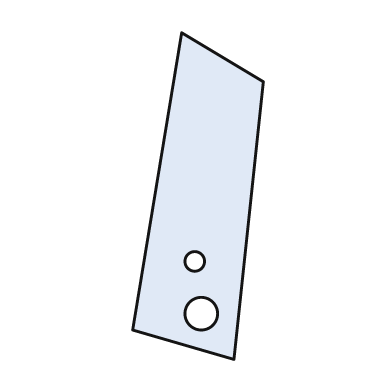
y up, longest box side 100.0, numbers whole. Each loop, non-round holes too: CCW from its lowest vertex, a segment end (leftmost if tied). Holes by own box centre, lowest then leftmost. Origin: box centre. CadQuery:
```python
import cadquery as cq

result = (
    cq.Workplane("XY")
    .moveTo(11.0, -50.0)
    .lineTo(20.0, 35.0)
    .lineTo(-5.0, 50.0)
    .lineTo(-20.0, -41.0)
    .close()
    .moveTo(1.0, -36.0)
    .circle(5.0)
    .moveTo(-1.0, -20.0)
    .circle(3.0)
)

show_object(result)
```